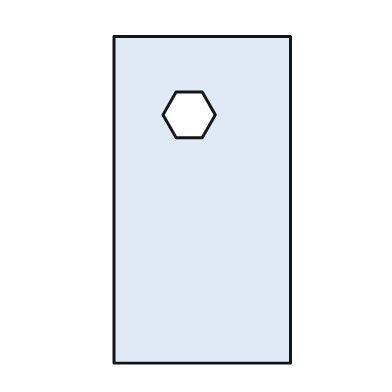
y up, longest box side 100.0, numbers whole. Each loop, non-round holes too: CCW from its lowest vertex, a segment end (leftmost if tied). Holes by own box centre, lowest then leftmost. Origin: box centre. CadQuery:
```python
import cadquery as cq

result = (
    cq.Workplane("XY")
    .moveTo(-27.0, -50.0)
    .lineTo(27.0, -50.0)
    .lineTo(27.0, 50.0)
    .lineTo(-27.0, 50.0)
    .close()
    .moveTo(-8.0, 19.0)
    .lineTo(0.0, 19.0)
    .lineTo(4.0, 26.0)
    .lineTo(0.0, 33.0)
    .lineTo(-8.0, 33.0)
    .lineTo(-12.0, 26.0)
    .close()
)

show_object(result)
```